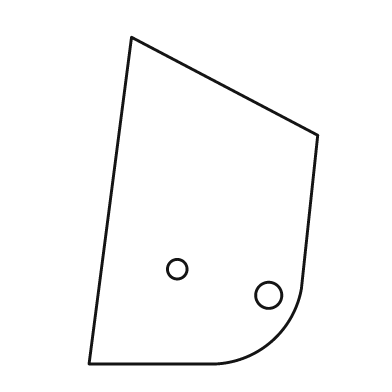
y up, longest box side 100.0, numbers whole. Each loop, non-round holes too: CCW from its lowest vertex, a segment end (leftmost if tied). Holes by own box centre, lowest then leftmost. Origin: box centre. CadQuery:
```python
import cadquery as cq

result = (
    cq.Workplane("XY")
    .moveTo(-35.0, -50.0)
    .lineTo(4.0, -50.0)
    .threePointArc((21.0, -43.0), (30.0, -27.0))
    .lineTo(35.0, 20.0)
    .lineTo(-22.0, 50.0)
    .close()
    .moveTo(20.0, -29.0)
    .circle(4.0)
    .moveTo(-8.0, -21.0)
    .circle(3.0)
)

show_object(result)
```